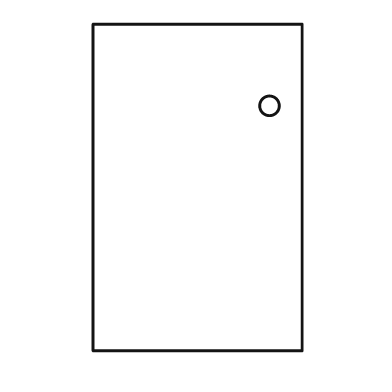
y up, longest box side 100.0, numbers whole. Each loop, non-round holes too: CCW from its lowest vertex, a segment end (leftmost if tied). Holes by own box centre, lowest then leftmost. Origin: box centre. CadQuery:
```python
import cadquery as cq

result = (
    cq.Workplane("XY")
    .moveTo(-32.0, -50.0)
    .lineTo(32.0, -50.0)
    .lineTo(32.0, 50.0)
    .lineTo(-32.0, 50.0)
    .close()
    .moveTo(22.0, 25.0)
    .circle(3.0)
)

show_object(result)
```